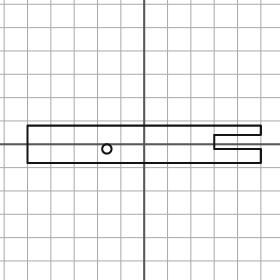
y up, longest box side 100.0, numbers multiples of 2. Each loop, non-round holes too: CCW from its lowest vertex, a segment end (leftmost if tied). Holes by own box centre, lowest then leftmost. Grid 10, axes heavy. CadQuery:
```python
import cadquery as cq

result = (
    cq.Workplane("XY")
    .moveTo(-50.0, -8.0)
    .lineTo(50.0, -8.0)
    .lineTo(50.0, -2.0)
    .lineTo(30.0, -2.0)
    .lineTo(30.0, 4.0)
    .lineTo(50.0, 4.0)
    .lineTo(50.0, 8.0)
    .lineTo(-50.0, 8.0)
    .close()
    .moveTo(-16.0, -2.0)
    .circle(2.0)
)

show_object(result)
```